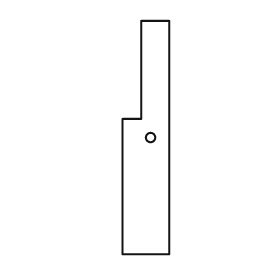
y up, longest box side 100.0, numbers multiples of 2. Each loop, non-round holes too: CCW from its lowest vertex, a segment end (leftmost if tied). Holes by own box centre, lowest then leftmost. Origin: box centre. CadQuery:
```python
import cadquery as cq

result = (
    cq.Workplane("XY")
    .moveTo(-10.0, -50.0)
    .lineTo(10.0, -50.0)
    .lineTo(10.0, 50.0)
    .lineTo(-2.0, 50.0)
    .lineTo(-2.0, 8.0)
    .lineTo(-10.0, 8.0)
    .close()
    .moveTo(2.0, 0.0)
    .circle(2.0)
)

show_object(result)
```